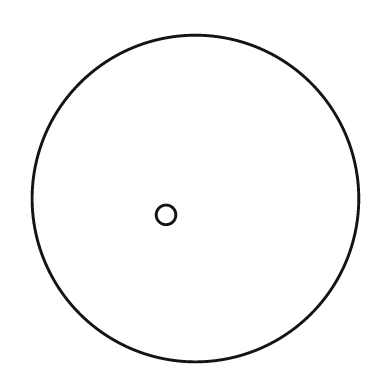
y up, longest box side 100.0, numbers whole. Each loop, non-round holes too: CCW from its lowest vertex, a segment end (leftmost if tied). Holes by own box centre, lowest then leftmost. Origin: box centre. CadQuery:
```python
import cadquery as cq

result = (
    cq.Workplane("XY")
    .moveTo(0.0, 0.0)
    .circle(50.0)
    .moveTo(-9.0, -5.0)
    .circle(3.0)
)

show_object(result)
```